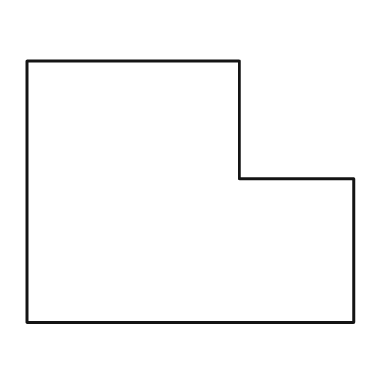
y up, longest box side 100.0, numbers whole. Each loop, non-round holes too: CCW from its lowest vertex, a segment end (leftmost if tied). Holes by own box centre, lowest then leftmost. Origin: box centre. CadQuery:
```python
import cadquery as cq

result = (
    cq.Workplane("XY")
    .moveTo(-50.0, -40.0)
    .lineTo(50.0, -40.0)
    .lineTo(50.0, 4.0)
    .lineTo(15.0, 4.0)
    .lineTo(15.0, 40.0)
    .lineTo(-50.0, 40.0)
    .close()
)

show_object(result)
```